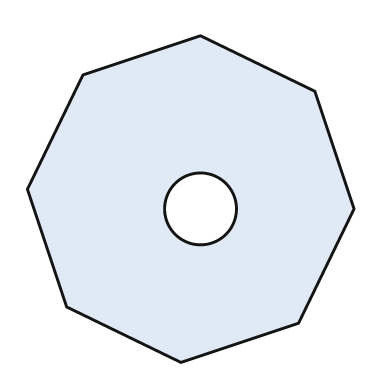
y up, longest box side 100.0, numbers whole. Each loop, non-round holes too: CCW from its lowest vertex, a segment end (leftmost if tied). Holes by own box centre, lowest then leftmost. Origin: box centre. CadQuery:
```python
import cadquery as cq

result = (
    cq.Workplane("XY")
    .moveTo(-3.0, -50.0)
    .lineTo(33.0, -38.0)
    .lineTo(50.0, -3.0)
    .lineTo(38.0, 33.0)
    .lineTo(3.0, 50.0)
    .lineTo(-33.0, 38.0)
    .lineTo(-50.0, 3.0)
    .lineTo(-38.0, -33.0)
    .close()
    .moveTo(3.0, -3.0)
    .circle(11.0)
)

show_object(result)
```